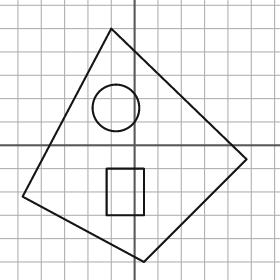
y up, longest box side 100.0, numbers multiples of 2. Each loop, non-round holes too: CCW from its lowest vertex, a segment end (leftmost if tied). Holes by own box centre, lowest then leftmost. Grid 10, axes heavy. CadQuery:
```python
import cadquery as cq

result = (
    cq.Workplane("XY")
    .moveTo(4.0, -50.0)
    .lineTo(48.0, -6.0)
    .lineTo(-10.0, 50.0)
    .lineTo(-48.0, -22.0)
    .close()
    .moveTo(-12.0, -30.0)
    .lineTo(4.0, -30.0)
    .lineTo(4.0, -10.0)
    .lineTo(-12.0, -10.0)
    .close()
    .moveTo(-8.0, 16.0)
    .circle(10.0)
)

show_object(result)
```